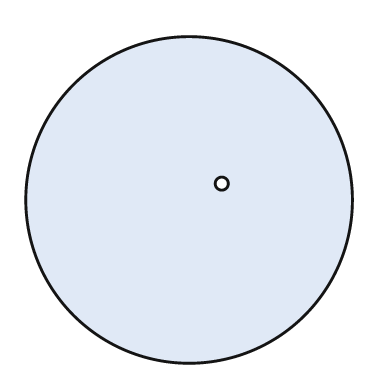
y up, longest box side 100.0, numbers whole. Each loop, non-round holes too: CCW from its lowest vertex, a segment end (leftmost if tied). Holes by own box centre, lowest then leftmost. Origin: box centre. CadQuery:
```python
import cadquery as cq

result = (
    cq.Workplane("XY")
    .moveTo(0.0, 0.0)
    .circle(50.0)
    .moveTo(10.0, 5.0)
    .circle(2.0)
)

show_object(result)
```